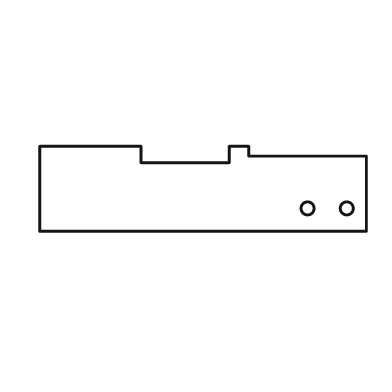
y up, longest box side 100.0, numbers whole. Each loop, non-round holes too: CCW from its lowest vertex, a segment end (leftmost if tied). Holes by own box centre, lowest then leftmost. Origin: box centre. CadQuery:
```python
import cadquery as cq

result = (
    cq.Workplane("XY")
    .moveTo(-50.0, -13.0)
    .lineTo(50.0, -13.0)
    .lineTo(50.0, 10.0)
    .lineTo(14.0, 10.0)
    .lineTo(14.0, 13.0)
    .lineTo(8.0, 13.0)
    .lineTo(8.0, 8.0)
    .lineTo(-19.0, 8.0)
    .lineTo(-19.0, 13.0)
    .lineTo(-50.0, 13.0)
    .close()
    .moveTo(32.0, -6.0)
    .circle(2.0)
    .moveTo(44.0, -6.0)
    .circle(2.0)
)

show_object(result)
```